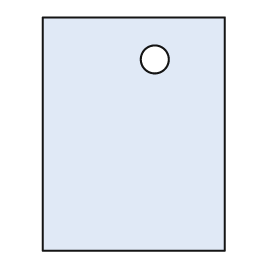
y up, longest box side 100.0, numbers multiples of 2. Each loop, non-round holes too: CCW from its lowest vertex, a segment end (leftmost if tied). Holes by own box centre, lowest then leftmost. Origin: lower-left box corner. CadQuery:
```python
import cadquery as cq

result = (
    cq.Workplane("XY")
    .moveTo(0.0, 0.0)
    .lineTo(78.0, 0.0)
    .lineTo(78.0, 100.0)
    .lineTo(0.0, 100.0)
    .close()
    .moveTo(48.0, 82.0)
    .circle(6.0)
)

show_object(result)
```